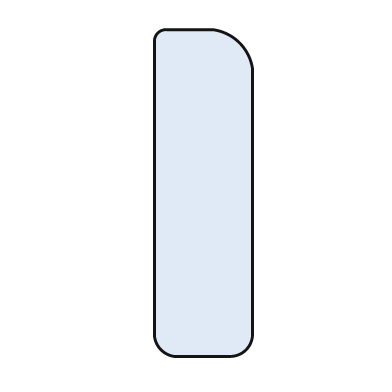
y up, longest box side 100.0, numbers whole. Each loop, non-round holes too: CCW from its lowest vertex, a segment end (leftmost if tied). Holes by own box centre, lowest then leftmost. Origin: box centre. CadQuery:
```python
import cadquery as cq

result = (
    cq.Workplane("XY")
    .moveTo(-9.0, -50.0)
    .lineTo(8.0, -50.0)
    .threePointArc((13.0, -48.0), (15.0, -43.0))
    .lineTo(15.0, 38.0)
    .threePointArc((11.0, 46.0), (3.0, 50.0))
    .lineTo(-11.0, 50.0)
    .threePointArc((-14.0, 49.0), (-15.0, 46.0))
    .lineTo(-15.0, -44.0)
    .threePointArc((-13.0, -48.0), (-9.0, -50.0))
    .close()
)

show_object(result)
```